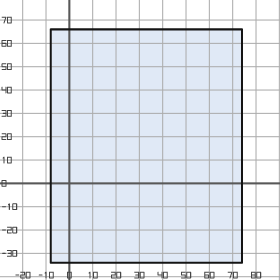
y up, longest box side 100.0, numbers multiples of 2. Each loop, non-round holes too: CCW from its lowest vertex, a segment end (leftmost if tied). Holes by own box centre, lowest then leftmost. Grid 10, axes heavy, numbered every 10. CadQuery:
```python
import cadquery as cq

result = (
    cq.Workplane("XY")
    .moveTo(-8.0, -34.0)
    .lineTo(74.0, -34.0)
    .lineTo(74.0, 66.0)
    .lineTo(-8.0, 66.0)
    .close()
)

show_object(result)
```